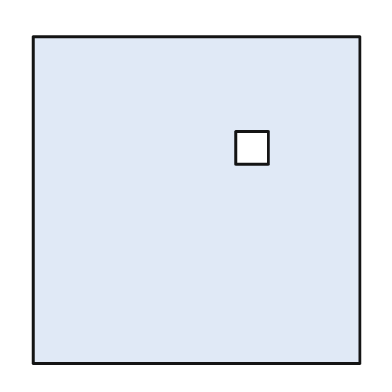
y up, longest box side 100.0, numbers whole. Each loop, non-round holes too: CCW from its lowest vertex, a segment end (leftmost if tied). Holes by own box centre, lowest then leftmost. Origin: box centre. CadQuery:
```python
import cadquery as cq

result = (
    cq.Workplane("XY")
    .moveTo(-50.0, -50.0)
    .lineTo(50.0, -50.0)
    .lineTo(50.0, 50.0)
    .lineTo(-50.0, 50.0)
    .close()
    .moveTo(12.0, 11.0)
    .lineTo(22.0, 11.0)
    .lineTo(22.0, 21.0)
    .lineTo(12.0, 21.0)
    .close()
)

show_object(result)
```